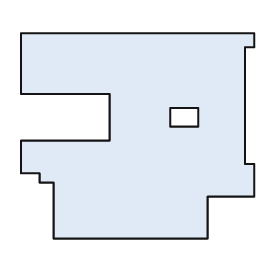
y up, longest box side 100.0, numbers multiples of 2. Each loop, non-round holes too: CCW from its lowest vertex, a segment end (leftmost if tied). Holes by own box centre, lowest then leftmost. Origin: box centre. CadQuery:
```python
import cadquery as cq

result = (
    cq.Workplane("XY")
    .moveTo(-36.0, -44.0)
    .lineTo(30.0, -44.0)
    .lineTo(30.0, -26.0)
    .lineTo(50.0, -26.0)
    .lineTo(50.0, -12.0)
    .lineTo(46.0, -12.0)
    .lineTo(46.0, 38.0)
    .lineTo(50.0, 38.0)
    .lineTo(50.0, 44.0)
    .lineTo(-50.0, 44.0)
    .lineTo(-50.0, 18.0)
    .lineTo(-12.0, 18.0)
    .lineTo(-12.0, -2.0)
    .lineTo(-50.0, -2.0)
    .lineTo(-50.0, -16.0)
    .lineTo(-42.0, -16.0)
    .lineTo(-42.0, -20.0)
    .lineTo(-36.0, -20.0)
    .close()
    .moveTo(14.0, 4.0)
    .lineTo(26.0, 4.0)
    .lineTo(26.0, 12.0)
    .lineTo(14.0, 12.0)
    .close()
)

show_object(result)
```